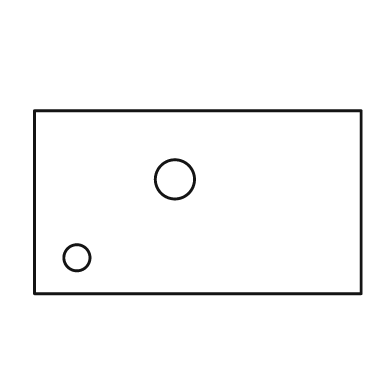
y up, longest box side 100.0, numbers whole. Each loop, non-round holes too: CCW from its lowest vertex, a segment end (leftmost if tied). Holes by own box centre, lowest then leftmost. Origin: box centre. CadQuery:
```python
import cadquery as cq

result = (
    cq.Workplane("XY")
    .moveTo(-50.0, -28.0)
    .lineTo(50.0, -28.0)
    .lineTo(50.0, 28.0)
    .lineTo(-50.0, 28.0)
    .close()
    .moveTo(-37.0, -17.0)
    .circle(4.0)
    .moveTo(-7.0, 7.0)
    .circle(6.0)
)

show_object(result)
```